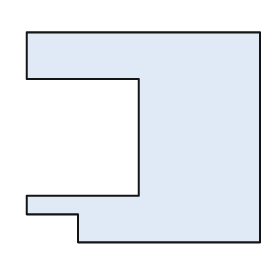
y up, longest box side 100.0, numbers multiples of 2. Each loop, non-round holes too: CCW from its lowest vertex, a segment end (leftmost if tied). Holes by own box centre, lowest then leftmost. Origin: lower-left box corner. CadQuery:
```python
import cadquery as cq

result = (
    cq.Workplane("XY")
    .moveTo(22.0, 0.0)
    .lineTo(100.0, 0.0)
    .lineTo(100.0, 90.0)
    .lineTo(0.0, 90.0)
    .lineTo(0.0, 70.0)
    .lineTo(48.0, 70.0)
    .lineTo(48.0, 20.0)
    .lineTo(0.0, 20.0)
    .lineTo(0.0, 12.0)
    .lineTo(22.0, 12.0)
    .close()
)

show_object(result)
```